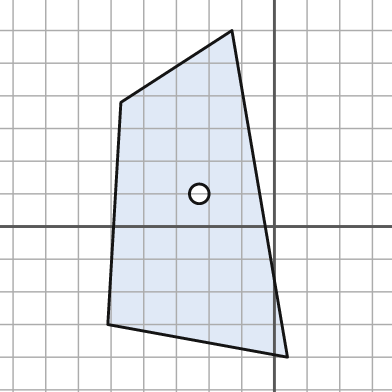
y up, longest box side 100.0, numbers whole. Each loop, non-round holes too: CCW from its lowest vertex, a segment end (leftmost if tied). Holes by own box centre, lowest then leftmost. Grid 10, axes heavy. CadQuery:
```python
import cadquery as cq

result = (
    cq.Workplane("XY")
    .moveTo(4.0, -40.0)
    .lineTo(-13.0, 60.0)
    .lineTo(-47.0, 38.0)
    .lineTo(-51.0, -30.0)
    .close()
    .moveTo(-23.0, 10.0)
    .circle(3.0)
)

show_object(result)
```